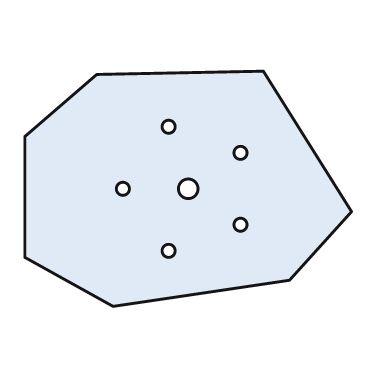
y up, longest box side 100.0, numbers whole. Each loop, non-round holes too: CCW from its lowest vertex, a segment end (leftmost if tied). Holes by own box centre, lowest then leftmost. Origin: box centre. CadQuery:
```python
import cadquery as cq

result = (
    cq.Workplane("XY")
    .moveTo(-23.0, -36.0)
    .lineTo(31.0, -28.0)
    .lineTo(50.0, -7.0)
    .lineTo(23.0, 36.0)
    .lineTo(-28.0, 35.0)
    .lineTo(-50.0, 16.0)
    .lineTo(-50.0, -21.0)
    .close()
    .moveTo(-6.0, -19.0)
    .circle(2.0)
    .moveTo(16.0, -11.0)
    .circle(2.0)
    .moveTo(-20.0, 0.0)
    .circle(2.0)
    .moveTo(0.0, 0.0)
    .circle(3.0)
    .moveTo(16.0, 11.0)
    .circle(2.0)
    .moveTo(-6.0, 19.0)
    .circle(2.0)
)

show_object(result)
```